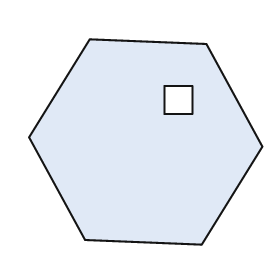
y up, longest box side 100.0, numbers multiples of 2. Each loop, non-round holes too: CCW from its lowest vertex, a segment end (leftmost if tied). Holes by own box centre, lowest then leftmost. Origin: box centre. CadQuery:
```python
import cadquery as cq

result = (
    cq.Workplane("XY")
    .moveTo(24.0, -44.0)
    .lineTo(50.0, -2.0)
    .lineTo(26.0, 42.0)
    .lineTo(-24.0, 44.0)
    .lineTo(-50.0, 2.0)
    .lineTo(-26.0, -42.0)
    .close()
    .moveTo(8.0, 12.0)
    .lineTo(20.0, 12.0)
    .lineTo(20.0, 24.0)
    .lineTo(8.0, 24.0)
    .close()
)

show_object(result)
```